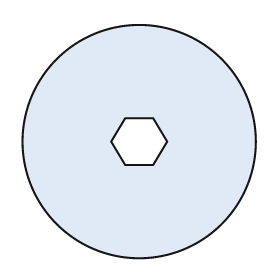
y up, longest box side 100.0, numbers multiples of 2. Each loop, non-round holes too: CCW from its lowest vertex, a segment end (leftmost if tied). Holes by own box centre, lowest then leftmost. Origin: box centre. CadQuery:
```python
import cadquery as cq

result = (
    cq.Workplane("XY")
    .moveTo(0.0, 0.0)
    .circle(50.0)
    .moveTo(-6.0, -10.0)
    .lineTo(6.0, -10.0)
    .lineTo(12.0, 0.0)
    .lineTo(6.0, 10.0)
    .lineTo(-6.0, 10.0)
    .lineTo(-12.0, 0.0)
    .close()
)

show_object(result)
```